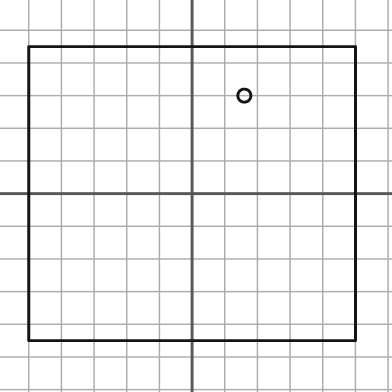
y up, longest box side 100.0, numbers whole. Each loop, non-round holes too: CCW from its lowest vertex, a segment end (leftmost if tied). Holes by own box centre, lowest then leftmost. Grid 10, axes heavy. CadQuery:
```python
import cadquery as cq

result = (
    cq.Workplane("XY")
    .moveTo(-50.0, -45.0)
    .lineTo(50.0, -45.0)
    .lineTo(50.0, 45.0)
    .lineTo(-50.0, 45.0)
    .close()
    .moveTo(16.0, 30.0)
    .circle(2.0)
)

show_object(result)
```